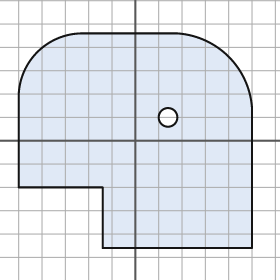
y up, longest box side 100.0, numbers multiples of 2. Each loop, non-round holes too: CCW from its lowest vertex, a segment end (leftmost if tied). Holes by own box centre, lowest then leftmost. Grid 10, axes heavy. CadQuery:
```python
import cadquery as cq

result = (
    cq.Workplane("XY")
    .moveTo(-14.0, -46.0)
    .lineTo(50.0, -46.0)
    .lineTo(50.0, 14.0)
    .threePointArc((40.0, 36.0), (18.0, 46.0))
    .lineTo(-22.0, 46.0)
    .threePointArc((-42.0, 38.0), (-50.0, 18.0))
    .lineTo(-50.0, -20.0)
    .lineTo(-14.0, -20.0)
    .close()
    .moveTo(14.0, 10.0)
    .circle(4.0)
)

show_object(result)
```